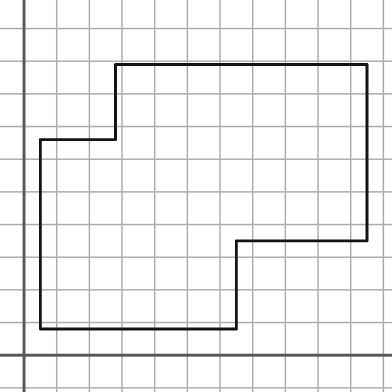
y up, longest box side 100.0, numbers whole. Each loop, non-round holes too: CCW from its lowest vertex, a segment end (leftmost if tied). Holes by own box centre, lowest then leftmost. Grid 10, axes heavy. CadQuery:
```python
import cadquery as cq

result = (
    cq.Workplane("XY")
    .moveTo(5.0, 8.0)
    .lineTo(65.0, 8.0)
    .lineTo(65.0, 35.0)
    .lineTo(105.0, 35.0)
    .lineTo(105.0, 89.0)
    .lineTo(28.0, 89.0)
    .lineTo(28.0, 66.0)
    .lineTo(5.0, 66.0)
    .close()
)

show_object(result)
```